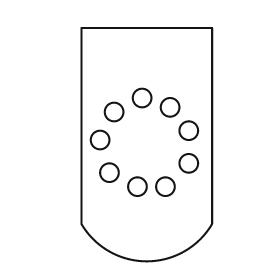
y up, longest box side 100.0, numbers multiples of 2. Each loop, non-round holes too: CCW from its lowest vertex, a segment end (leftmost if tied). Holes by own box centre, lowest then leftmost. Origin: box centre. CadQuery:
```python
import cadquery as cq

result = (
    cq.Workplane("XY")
    .moveTo(-28.0, -34.0)
    .threePointArc((0.0, -50.0), (28.0, -34.0))
    .lineTo(28.0, 50.0)
    .lineTo(-28.0, 50.0)
    .close()
    .moveTo(-4.0, -18.0)
    .circle(4.0)
    .moveTo(8.0, -18.0)
    .circle(4.0)
    .moveTo(-16.0, -12.0)
    .circle(4.0)
    .moveTo(18.0, -8.0)
    .circle(4.0)
    .moveTo(-20.0, 2.0)
    .circle(4.0)
    .moveTo(18.0, 6.0)
    .circle(4.0)
    .moveTo(-14.0, 14.0)
    .circle(4.0)
    .moveTo(10.0, 16.0)
    .circle(4.0)
    .moveTo(-2.0, 20.0)
    .circle(4.0)
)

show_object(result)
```